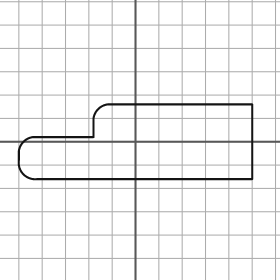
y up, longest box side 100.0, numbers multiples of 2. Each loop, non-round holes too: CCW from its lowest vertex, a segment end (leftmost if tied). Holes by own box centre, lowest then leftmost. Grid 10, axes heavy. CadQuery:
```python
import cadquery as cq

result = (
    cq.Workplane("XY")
    .moveTo(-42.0, -16.0)
    .lineTo(50.0, -16.0)
    .lineTo(50.0, 16.0)
    .lineTo(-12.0, 16.0)
    .threePointArc((-16.0, 14.0), (-18.0, 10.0))
    .lineTo(-18.0, 2.0)
    .lineTo(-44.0, 2.0)
    .threePointArc((-48.0, 0.0), (-50.0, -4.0))
    .lineTo(-50.0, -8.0)
    .threePointArc((-48.0, -14.0), (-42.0, -16.0))
    .close()
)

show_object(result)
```